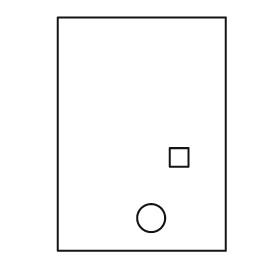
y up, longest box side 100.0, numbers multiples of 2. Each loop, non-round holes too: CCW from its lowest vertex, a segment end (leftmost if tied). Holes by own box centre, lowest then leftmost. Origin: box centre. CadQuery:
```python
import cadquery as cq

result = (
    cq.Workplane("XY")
    .moveTo(-36.0, -50.0)
    .lineTo(36.0, -50.0)
    .lineTo(36.0, 50.0)
    .lineTo(-36.0, 50.0)
    .close()
    .moveTo(4.0, -36.0)
    .circle(6.0)
    .moveTo(12.0, -14.0)
    .lineTo(20.0, -14.0)
    .lineTo(20.0, -6.0)
    .lineTo(12.0, -6.0)
    .close()
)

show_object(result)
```